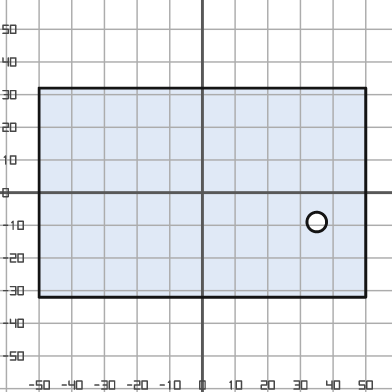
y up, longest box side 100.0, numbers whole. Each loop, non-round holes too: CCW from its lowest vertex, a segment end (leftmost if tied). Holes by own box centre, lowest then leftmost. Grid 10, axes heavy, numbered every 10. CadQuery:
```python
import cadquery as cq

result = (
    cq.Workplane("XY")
    .moveTo(-50.0, -32.0)
    .lineTo(50.0, -32.0)
    .lineTo(50.0, 32.0)
    .lineTo(-50.0, 32.0)
    .close()
    .moveTo(35.0, -9.0)
    .circle(3.0)
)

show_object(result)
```